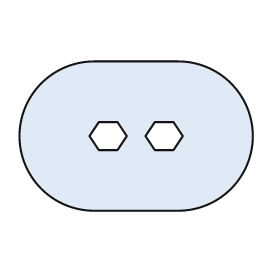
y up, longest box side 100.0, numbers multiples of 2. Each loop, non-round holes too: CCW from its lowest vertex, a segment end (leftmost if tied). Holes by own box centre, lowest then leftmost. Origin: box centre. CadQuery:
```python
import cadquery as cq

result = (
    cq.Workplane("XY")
    .moveTo(-18.0, -32.0)
    .lineTo(18.0, -32.0)
    .threePointArc((50.0, 0.0), (18.0, 32.0))
    .lineTo(-18.0, 32.0)
    .threePointArc((-50.0, 0.0), (-18.0, -32.0))
    .close()
    .moveTo(-16.0, -6.0)
    .lineTo(-8.0, -6.0)
    .lineTo(-4.0, 0.0)
    .lineTo(-8.0, 6.0)
    .lineTo(-16.0, 6.0)
    .lineTo(-20.0, 0.0)
    .close()
    .moveTo(8.0, -6.0)
    .lineTo(16.0, -6.0)
    .lineTo(20.0, 0.0)
    .lineTo(16.0, 6.0)
    .lineTo(8.0, 6.0)
    .lineTo(4.0, 0.0)
    .close()
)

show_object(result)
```